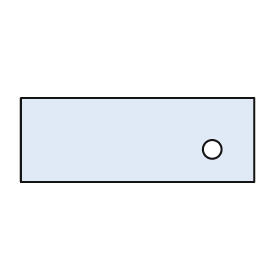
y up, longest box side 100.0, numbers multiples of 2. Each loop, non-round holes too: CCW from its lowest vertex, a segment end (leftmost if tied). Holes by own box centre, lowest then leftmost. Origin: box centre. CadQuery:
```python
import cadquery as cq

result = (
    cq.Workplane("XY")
    .moveTo(-50.0, -18.0)
    .lineTo(50.0, -18.0)
    .lineTo(50.0, 18.0)
    .lineTo(-50.0, 18.0)
    .close()
    .moveTo(32.0, -4.0)
    .circle(4.0)
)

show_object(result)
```